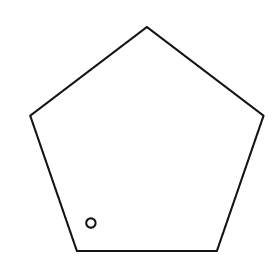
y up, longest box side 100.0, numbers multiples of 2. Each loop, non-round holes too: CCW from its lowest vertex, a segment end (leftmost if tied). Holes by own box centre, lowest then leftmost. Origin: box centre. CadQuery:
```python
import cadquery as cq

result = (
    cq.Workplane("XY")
    .moveTo(-30.0, -48.0)
    .lineTo(30.0, -48.0)
    .lineTo(50.0, 10.0)
    .lineTo(0.0, 48.0)
    .lineTo(-50.0, 10.0)
    .close()
    .moveTo(-24.0, -36.0)
    .circle(2.0)
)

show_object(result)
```